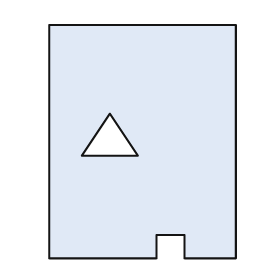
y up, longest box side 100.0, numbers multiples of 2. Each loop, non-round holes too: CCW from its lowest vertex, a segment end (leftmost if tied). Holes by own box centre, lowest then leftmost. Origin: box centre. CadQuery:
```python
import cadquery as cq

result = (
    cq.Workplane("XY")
    .moveTo(-40.0, -50.0)
    .lineTo(6.0, -50.0)
    .lineTo(6.0, -40.0)
    .lineTo(18.0, -40.0)
    .lineTo(18.0, -50.0)
    .lineTo(40.0, -50.0)
    .lineTo(40.0, 50.0)
    .lineTo(-40.0, 50.0)
    .close()
    .moveTo(-26.0, -6.0)
    .lineTo(-2.0, -6.0)
    .lineTo(-14.0, 12.0)
    .close()
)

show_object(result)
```